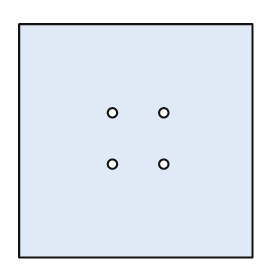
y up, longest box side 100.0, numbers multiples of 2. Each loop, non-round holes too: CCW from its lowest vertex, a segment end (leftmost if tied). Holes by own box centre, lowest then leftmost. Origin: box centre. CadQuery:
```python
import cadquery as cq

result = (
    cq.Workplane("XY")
    .moveTo(-50.0, -50.0)
    .lineTo(50.0, -50.0)
    .lineTo(50.0, 50.0)
    .lineTo(-50.0, 50.0)
    .close()
    .moveTo(-10.0, -10.0)
    .circle(2.0)
    .moveTo(12.0, -10.0)
    .circle(2.0)
    .moveTo(-10.0, 12.0)
    .circle(2.0)
    .moveTo(12.0, 12.0)
    .circle(2.0)
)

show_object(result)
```